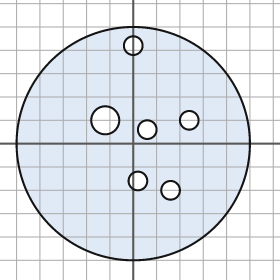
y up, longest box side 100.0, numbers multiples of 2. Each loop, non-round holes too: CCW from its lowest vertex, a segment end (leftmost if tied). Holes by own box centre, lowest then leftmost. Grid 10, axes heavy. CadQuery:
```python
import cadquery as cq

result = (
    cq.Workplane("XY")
    .moveTo(0.0, 0.0)
    .circle(50.0)
    .moveTo(16.0, -20.0)
    .circle(4.0)
    .moveTo(2.0, -16.0)
    .circle(4.0)
    .moveTo(6.0, 6.0)
    .circle(4.0)
    .moveTo(-12.0, 10.0)
    .circle(6.0)
    .moveTo(24.0, 10.0)
    .circle(4.0)
    .moveTo(0.0, 42.0)
    .circle(4.0)
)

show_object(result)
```